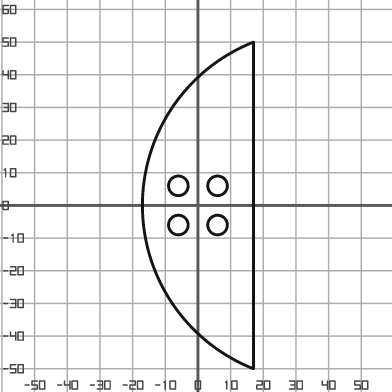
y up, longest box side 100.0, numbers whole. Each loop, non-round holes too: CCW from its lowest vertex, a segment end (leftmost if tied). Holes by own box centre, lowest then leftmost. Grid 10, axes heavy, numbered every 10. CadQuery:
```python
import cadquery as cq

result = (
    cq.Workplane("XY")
    .moveTo(17.0, -50.0)
    .lineTo(17.0, 50.0)
    .threePointArc((-17.0, 0.0), (17.0, -50.0))
    .close()
    .moveTo(-6.0, -6.0)
    .circle(3.0)
    .moveTo(6.0, -6.0)
    .circle(3.0)
    .moveTo(-6.0, 6.0)
    .circle(3.0)
    .moveTo(6.0, 6.0)
    .circle(3.0)
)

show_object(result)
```